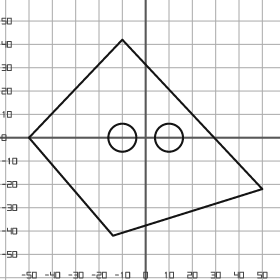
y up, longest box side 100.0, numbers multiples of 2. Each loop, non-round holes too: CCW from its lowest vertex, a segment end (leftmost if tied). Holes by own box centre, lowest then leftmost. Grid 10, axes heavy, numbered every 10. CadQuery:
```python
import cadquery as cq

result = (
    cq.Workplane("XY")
    .moveTo(-14.0, -42.0)
    .lineTo(50.0, -22.0)
    .lineTo(-10.0, 42.0)
    .lineTo(-50.0, 0.0)
    .close()
    .moveTo(-10.0, 0.0)
    .circle(6.0)
    .moveTo(10.0, 0.0)
    .circle(6.0)
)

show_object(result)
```